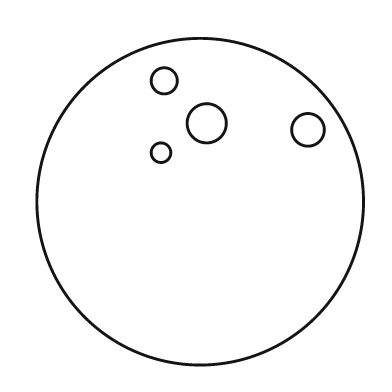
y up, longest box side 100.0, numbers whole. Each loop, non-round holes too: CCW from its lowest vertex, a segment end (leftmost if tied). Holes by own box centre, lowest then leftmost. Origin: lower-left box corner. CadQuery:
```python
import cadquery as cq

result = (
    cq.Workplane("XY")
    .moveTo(50.0, 50.0)
    .circle(50.0)
    .moveTo(38.0, 65.0)
    .circle(3.0)
    .moveTo(83.0, 72.0)
    .circle(5.0)
    .moveTo(52.0, 74.0)
    .circle(6.0)
    .moveTo(39.0, 87.0)
    .circle(4.0)
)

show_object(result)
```